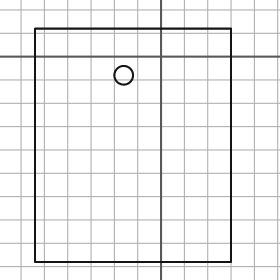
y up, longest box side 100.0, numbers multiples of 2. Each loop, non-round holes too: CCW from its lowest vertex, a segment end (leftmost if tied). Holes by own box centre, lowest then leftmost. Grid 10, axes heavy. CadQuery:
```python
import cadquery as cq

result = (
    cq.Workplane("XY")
    .moveTo(-54.0, -88.0)
    .lineTo(30.0, -88.0)
    .lineTo(30.0, 12.0)
    .lineTo(-54.0, 12.0)
    .close()
    .moveTo(-16.0, -8.0)
    .circle(4.0)
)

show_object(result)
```